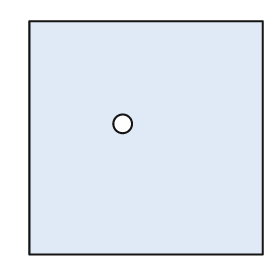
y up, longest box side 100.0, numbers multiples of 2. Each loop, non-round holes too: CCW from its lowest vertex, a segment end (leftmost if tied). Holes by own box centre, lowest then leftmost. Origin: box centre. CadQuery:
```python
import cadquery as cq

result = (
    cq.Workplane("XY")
    .moveTo(-50.0, -50.0)
    .lineTo(50.0, -50.0)
    .lineTo(50.0, 50.0)
    .lineTo(-50.0, 50.0)
    .close()
    .moveTo(-10.0, 6.0)
    .circle(4.0)
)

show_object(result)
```